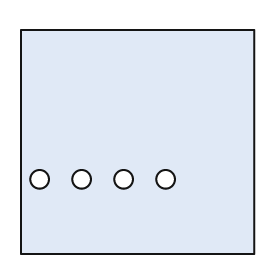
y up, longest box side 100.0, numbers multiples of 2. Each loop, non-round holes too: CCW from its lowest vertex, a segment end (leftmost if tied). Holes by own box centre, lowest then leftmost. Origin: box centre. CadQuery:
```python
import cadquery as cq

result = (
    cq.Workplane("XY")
    .moveTo(-50.0, -48.0)
    .lineTo(50.0, -48.0)
    .lineTo(50.0, 48.0)
    .lineTo(-50.0, 48.0)
    .close()
    .moveTo(-42.0, -16.0)
    .circle(4.0)
    .moveTo(-24.0, -16.0)
    .circle(4.0)
    .moveTo(-6.0, -16.0)
    .circle(4.0)
    .moveTo(12.0, -16.0)
    .circle(4.0)
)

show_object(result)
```